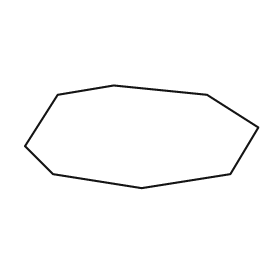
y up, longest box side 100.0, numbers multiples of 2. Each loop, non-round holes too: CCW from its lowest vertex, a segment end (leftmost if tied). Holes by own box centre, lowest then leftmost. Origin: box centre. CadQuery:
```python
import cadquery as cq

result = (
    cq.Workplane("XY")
    .moveTo(0.0, -22.0)
    .lineTo(38.0, -16.0)
    .lineTo(50.0, 4.0)
    .lineTo(28.0, 18.0)
    .lineTo(-12.0, 22.0)
    .lineTo(-36.0, 18.0)
    .lineTo(-50.0, -4.0)
    .lineTo(-38.0, -16.0)
    .close()
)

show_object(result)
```